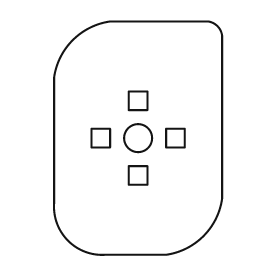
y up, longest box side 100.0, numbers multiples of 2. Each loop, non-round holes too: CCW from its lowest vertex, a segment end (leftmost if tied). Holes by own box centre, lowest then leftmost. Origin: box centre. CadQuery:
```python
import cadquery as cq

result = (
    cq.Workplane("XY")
    .moveTo(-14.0, -50.0)
    .lineTo(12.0, -50.0)
    .threePointArc((28.0, -42.0), (36.0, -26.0))
    .lineTo(36.0, 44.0)
    .threePointArc((34.0, 48.0), (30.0, 50.0))
    .lineTo(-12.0, 50.0)
    .threePointArc((-28.0, 42.0), (-36.0, 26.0))
    .lineTo(-36.0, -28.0)
    .threePointArc((-30.0, -44.0), (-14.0, -50.0))
    .close()
    .moveTo(-4.0, -20.0)
    .lineTo(4.0, -20.0)
    .lineTo(4.0, -12.0)
    .lineTo(-4.0, -12.0)
    .close()
    .moveTo(-20.0, -4.0)
    .lineTo(-12.0, -4.0)
    .lineTo(-12.0, 4.0)
    .lineTo(-20.0, 4.0)
    .close()
    .moveTo(0.0, 0.0)
    .circle(6.0)
    .moveTo(12.0, -4.0)
    .lineTo(20.0, -4.0)
    .lineTo(20.0, 4.0)
    .lineTo(12.0, 4.0)
    .close()
    .moveTo(-4.0, 12.0)
    .lineTo(4.0, 12.0)
    .lineTo(4.0, 20.0)
    .lineTo(-4.0, 20.0)
    .close()
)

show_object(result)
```